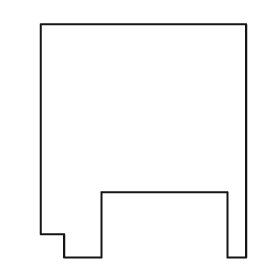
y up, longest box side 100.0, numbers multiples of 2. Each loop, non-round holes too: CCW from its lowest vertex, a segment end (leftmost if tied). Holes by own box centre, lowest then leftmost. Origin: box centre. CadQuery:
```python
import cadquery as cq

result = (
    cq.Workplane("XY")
    .moveTo(-34.0, -50.0)
    .lineTo(-18.0, -50.0)
    .lineTo(-18.0, -22.0)
    .lineTo(36.0, -22.0)
    .lineTo(36.0, -50.0)
    .lineTo(44.0, -50.0)
    .lineTo(44.0, 50.0)
    .lineTo(-44.0, 50.0)
    .lineTo(-44.0, -40.0)
    .lineTo(-34.0, -40.0)
    .close()
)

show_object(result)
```